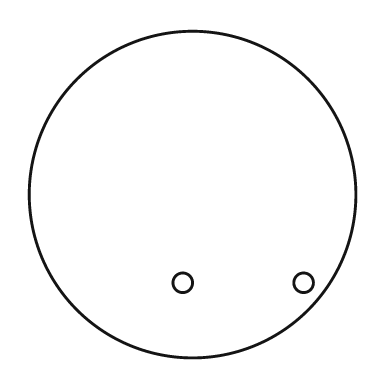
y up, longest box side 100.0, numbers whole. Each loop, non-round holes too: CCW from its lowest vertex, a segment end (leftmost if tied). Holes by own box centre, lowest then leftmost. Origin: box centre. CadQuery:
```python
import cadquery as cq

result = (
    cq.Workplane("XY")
    .moveTo(0.0, 0.0)
    .circle(50.0)
    .moveTo(-3.0, -27.0)
    .circle(3.0)
    .moveTo(34.0, -27.0)
    .circle(3.0)
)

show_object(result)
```